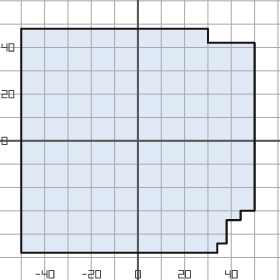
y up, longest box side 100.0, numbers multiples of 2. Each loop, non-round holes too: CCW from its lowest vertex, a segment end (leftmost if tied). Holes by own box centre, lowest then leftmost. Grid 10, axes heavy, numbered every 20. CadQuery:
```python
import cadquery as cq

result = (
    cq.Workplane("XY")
    .moveTo(-50.0, -48.0)
    .lineTo(34.0, -48.0)
    .lineTo(34.0, -44.0)
    .lineTo(38.0, -44.0)
    .lineTo(38.0, -34.0)
    .lineTo(44.0, -34.0)
    .lineTo(44.0, -30.0)
    .lineTo(50.0, -30.0)
    .lineTo(50.0, 42.0)
    .lineTo(30.0, 42.0)
    .lineTo(30.0, 48.0)
    .lineTo(-50.0, 48.0)
    .close()
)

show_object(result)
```